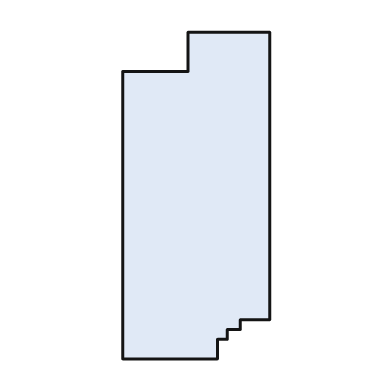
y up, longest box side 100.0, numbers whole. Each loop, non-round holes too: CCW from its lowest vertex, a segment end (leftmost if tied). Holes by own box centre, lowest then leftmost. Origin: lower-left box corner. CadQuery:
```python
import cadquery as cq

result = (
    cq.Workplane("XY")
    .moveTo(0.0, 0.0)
    .lineTo(29.0, 0.0)
    .lineTo(29.0, 6.0)
    .lineTo(32.0, 6.0)
    .lineTo(32.0, 9.0)
    .lineTo(36.0, 9.0)
    .lineTo(36.0, 12.0)
    .lineTo(45.0, 12.0)
    .lineTo(45.0, 100.0)
    .lineTo(20.0, 100.0)
    .lineTo(20.0, 88.0)
    .lineTo(0.0, 88.0)
    .close()
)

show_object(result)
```